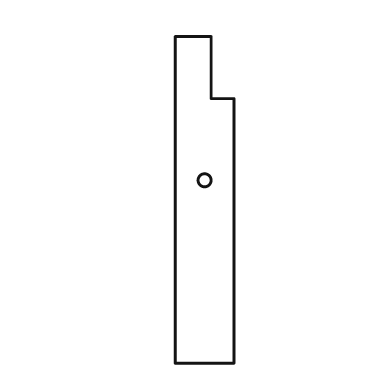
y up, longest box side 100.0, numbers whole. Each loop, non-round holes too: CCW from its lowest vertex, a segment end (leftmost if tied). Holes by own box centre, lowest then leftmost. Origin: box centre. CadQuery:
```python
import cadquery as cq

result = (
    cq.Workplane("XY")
    .moveTo(-9.0, -50.0)
    .lineTo(9.0, -50.0)
    .lineTo(9.0, 31.0)
    .lineTo(2.0, 31.0)
    .lineTo(2.0, 50.0)
    .lineTo(-9.0, 50.0)
    .close()
    .moveTo(0.0, 6.0)
    .circle(2.0)
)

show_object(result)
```